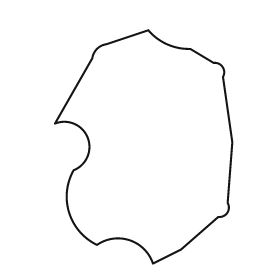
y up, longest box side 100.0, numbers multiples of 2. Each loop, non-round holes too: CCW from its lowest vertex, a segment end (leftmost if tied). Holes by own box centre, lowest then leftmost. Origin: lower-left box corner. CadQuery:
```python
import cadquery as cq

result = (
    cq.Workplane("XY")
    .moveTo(42.0, 0.0)
    .lineTo(54.0, 6.0)
    .lineTo(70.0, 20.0)
    .threePointArc((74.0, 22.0), (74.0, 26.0))
    .lineTo(76.0, 52.0)
    .lineTo(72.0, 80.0)
    .threePointArc((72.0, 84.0), (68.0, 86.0))
    .lineTo(58.0, 92.0)
    .threePointArc((48.0, 94.0), (40.0, 100.0))
    .lineTo(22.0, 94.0)
    .threePointArc((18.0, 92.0), (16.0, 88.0))
    .lineTo(0.0, 60.0)
    .threePointArc((14.0, 54.0), (8.0, 40.0))
    .threePointArc((6.0, 22.0), (18.0, 8.0))
    .threePointArc((32.0, 10.0), (42.0, 0.0))
    .close()
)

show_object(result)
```